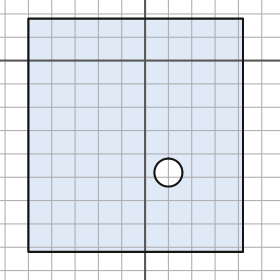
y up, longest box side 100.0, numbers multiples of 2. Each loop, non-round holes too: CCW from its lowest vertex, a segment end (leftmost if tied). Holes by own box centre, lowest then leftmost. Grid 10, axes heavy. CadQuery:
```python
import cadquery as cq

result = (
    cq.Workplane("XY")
    .moveTo(-50.0, -82.0)
    .lineTo(42.0, -82.0)
    .lineTo(42.0, 18.0)
    .lineTo(-50.0, 18.0)
    .close()
    .moveTo(10.0, -48.0)
    .circle(6.0)
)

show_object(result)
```